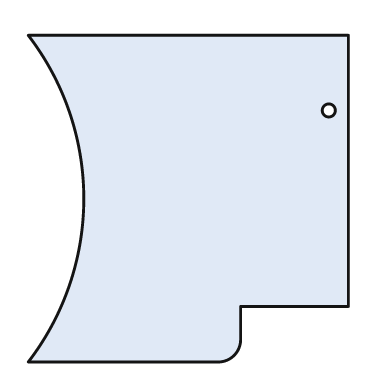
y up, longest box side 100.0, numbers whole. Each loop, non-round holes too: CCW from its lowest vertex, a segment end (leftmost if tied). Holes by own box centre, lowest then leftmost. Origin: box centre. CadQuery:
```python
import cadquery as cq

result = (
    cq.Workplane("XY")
    .moveTo(-49.0, -50.0)
    .lineTo(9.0, -50.0)
    .threePointArc((14.0, -48.0), (16.0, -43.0))
    .lineTo(16.0, -33.0)
    .lineTo(49.0, -33.0)
    .lineTo(49.0, 50.0)
    .lineTo(-49.0, 50.0)
    .threePointArc((-32.0, 0.0), (-49.0, -50.0))
    .close()
    .moveTo(43.0, 27.0)
    .circle(2.0)
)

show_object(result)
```